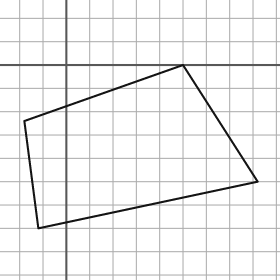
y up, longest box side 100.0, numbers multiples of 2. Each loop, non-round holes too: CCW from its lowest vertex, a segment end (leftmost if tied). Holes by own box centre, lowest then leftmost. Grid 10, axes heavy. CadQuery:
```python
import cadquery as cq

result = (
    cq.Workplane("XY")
    .moveTo(-12.0, -70.0)
    .lineTo(82.0, -50.0)
    .lineTo(50.0, 0.0)
    .lineTo(-18.0, -24.0)
    .close()
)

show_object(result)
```